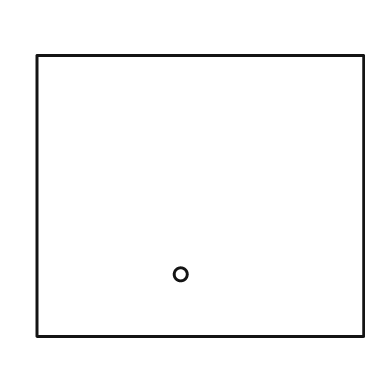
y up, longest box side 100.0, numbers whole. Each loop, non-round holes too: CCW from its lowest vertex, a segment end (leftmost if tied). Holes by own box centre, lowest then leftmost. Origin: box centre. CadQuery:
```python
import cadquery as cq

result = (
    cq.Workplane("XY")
    .moveTo(-50.0, -43.0)
    .lineTo(50.0, -43.0)
    .lineTo(50.0, 43.0)
    .lineTo(-50.0, 43.0)
    .close()
    .moveTo(-6.0, -24.0)
    .circle(2.0)
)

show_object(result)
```